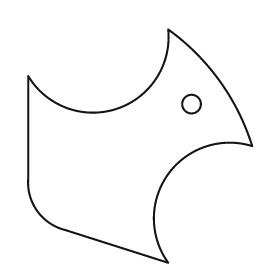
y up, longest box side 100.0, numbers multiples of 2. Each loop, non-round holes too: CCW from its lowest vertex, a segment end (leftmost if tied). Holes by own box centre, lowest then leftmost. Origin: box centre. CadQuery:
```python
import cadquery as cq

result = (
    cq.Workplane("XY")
    .moveTo(12.0, -50.0)
    .threePointArc((12.0, -12.0), (48.0, 0.0))
    .threePointArc((34.0, 28.0), (12.0, 50.0))
    .threePointArc((-10.0, 16.0), (-48.0, 30.0))
    .lineTo(-48.0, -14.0)
    .threePointArc((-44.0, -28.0), (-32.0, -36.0))
    .close()
    .moveTo(22.0, 18.0)
    .circle(4.0)
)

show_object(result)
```